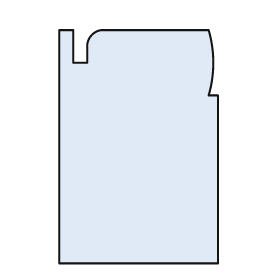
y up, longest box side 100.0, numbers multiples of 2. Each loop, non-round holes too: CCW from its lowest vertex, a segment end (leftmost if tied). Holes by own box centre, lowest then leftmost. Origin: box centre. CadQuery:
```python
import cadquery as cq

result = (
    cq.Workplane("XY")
    .moveTo(-34.0, -50.0)
    .lineTo(34.0, -50.0)
    .lineTo(34.0, 22.0)
    .lineTo(30.0, 22.0)
    .threePointArc((32.0, 36.0), (30.0, 50.0))
    .lineTo(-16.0, 50.0)
    .threePointArc((-20.0, 48.0), (-22.0, 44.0))
    .lineTo(-22.0, 36.0)
    .lineTo(-28.0, 36.0)
    .lineTo(-28.0, 50.0)
    .lineTo(-34.0, 50.0)
    .close()
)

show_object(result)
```